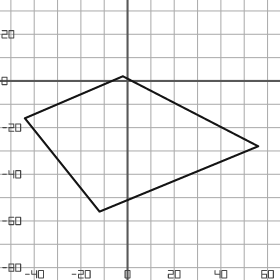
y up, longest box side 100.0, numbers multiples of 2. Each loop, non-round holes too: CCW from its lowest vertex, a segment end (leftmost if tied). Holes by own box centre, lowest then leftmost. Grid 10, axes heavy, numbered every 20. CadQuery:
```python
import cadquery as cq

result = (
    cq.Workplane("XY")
    .moveTo(-12.0, -56.0)
    .lineTo(56.0, -28.0)
    .lineTo(-2.0, 2.0)
    .lineTo(-44.0, -16.0)
    .close()
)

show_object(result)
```